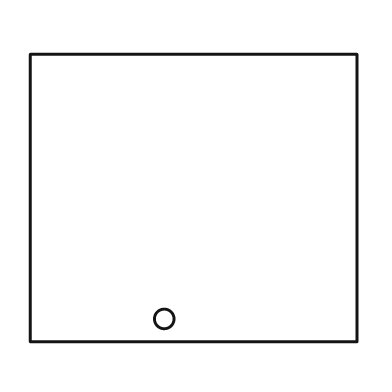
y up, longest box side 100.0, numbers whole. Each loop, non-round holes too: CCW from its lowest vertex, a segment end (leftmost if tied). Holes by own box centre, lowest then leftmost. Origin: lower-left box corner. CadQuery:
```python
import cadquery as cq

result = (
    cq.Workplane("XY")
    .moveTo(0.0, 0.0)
    .lineTo(100.0, 0.0)
    .lineTo(100.0, 88.0)
    .lineTo(0.0, 88.0)
    .close()
    .moveTo(41.0, 7.0)
    .circle(3.0)
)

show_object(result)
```